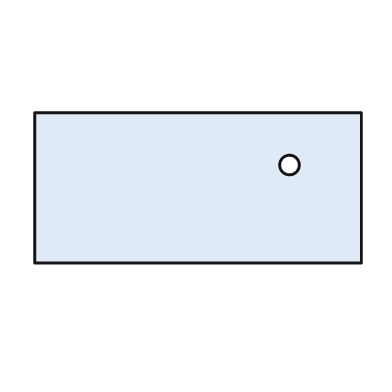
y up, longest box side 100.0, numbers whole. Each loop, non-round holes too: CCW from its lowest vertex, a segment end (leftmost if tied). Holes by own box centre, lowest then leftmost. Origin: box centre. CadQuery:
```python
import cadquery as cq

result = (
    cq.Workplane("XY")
    .moveTo(-50.0, -23.0)
    .lineTo(50.0, -23.0)
    .lineTo(50.0, 23.0)
    .lineTo(-50.0, 23.0)
    .close()
    .moveTo(28.0, 7.0)
    .circle(3.0)
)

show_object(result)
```